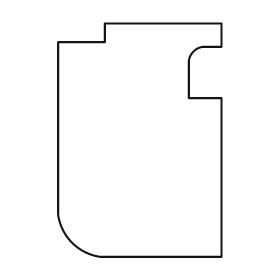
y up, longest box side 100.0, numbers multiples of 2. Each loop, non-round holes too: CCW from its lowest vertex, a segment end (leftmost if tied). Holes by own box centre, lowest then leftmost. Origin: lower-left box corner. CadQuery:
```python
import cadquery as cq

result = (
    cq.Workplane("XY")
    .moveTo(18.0, 0.0)
    .lineTo(70.0, 0.0)
    .lineTo(70.0, 68.0)
    .lineTo(56.0, 68.0)
    .lineTo(56.0, 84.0)
    .threePointArc((58.0, 88.0), (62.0, 90.0))
    .lineTo(70.0, 90.0)
    .lineTo(70.0, 100.0)
    .lineTo(20.0, 100.0)
    .lineTo(20.0, 92.0)
    .lineTo(0.0, 92.0)
    .lineTo(0.0, 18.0)
    .threePointArc((6.0, 6.0), (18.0, 0.0))
    .close()
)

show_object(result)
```